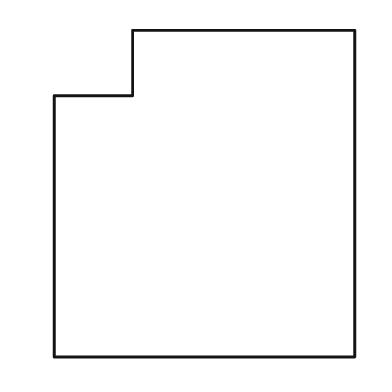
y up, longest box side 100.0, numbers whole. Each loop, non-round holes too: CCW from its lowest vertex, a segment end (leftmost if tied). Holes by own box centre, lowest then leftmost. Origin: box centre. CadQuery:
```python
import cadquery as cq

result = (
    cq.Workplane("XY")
    .moveTo(-46.0, -50.0)
    .lineTo(46.0, -50.0)
    .lineTo(46.0, 50.0)
    .lineTo(-22.0, 50.0)
    .lineTo(-22.0, 30.0)
    .lineTo(-46.0, 30.0)
    .close()
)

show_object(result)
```